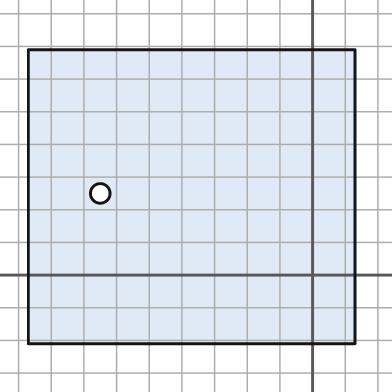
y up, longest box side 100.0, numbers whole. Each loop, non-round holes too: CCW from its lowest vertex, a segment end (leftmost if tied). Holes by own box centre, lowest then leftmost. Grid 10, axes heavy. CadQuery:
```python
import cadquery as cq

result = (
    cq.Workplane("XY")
    .moveTo(-87.0, -21.0)
    .lineTo(13.0, -21.0)
    .lineTo(13.0, 69.0)
    .lineTo(-87.0, 69.0)
    .close()
    .moveTo(-65.0, 25.0)
    .circle(3.0)
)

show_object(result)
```